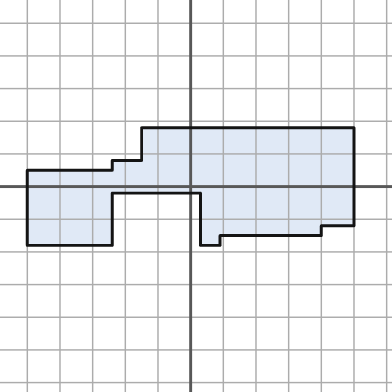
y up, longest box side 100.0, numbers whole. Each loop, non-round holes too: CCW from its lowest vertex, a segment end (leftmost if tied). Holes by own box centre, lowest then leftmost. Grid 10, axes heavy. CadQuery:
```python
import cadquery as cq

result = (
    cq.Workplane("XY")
    .moveTo(-50.0, -18.0)
    .lineTo(-24.0, -18.0)
    .lineTo(-24.0, -2.0)
    .lineTo(3.0, -2.0)
    .lineTo(3.0, -18.0)
    .lineTo(9.0, -18.0)
    .lineTo(9.0, -15.0)
    .lineTo(40.0, -15.0)
    .lineTo(40.0, -12.0)
    .lineTo(50.0, -12.0)
    .lineTo(50.0, 18.0)
    .lineTo(-15.0, 18.0)
    .lineTo(-15.0, 8.0)
    .lineTo(-24.0, 8.0)
    .lineTo(-24.0, 5.0)
    .lineTo(-50.0, 5.0)
    .close()
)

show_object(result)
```